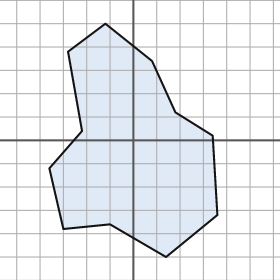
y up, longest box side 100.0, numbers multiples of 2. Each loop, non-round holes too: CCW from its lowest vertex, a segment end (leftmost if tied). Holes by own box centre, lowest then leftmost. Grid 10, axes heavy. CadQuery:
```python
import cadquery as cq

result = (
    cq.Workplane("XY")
    .moveTo(14.0, -50.0)
    .lineTo(36.0, -32.0)
    .lineTo(34.0, 2.0)
    .lineTo(18.0, 12.0)
    .lineTo(8.0, 34.0)
    .lineTo(-12.0, 50.0)
    .lineTo(-28.0, 38.0)
    .lineTo(-22.0, 4.0)
    .lineTo(-36.0, -12.0)
    .lineTo(-30.0, -38.0)
    .lineTo(-10.0, -36.0)
    .close()
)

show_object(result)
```